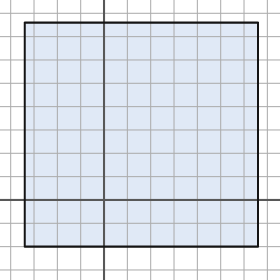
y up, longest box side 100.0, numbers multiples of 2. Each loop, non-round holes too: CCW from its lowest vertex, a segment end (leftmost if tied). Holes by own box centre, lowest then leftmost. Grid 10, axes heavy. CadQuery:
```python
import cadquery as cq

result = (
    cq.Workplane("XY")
    .moveTo(-34.0, -20.0)
    .lineTo(66.0, -20.0)
    .lineTo(66.0, 76.0)
    .lineTo(-34.0, 76.0)
    .close()
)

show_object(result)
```